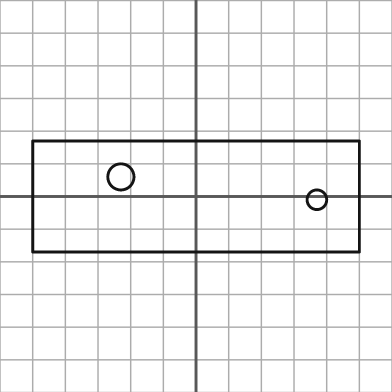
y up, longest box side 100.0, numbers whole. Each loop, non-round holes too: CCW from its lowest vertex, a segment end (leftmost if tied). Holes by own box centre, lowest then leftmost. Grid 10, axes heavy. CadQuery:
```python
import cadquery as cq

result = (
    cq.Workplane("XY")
    .moveTo(-50.0, -17.0)
    .lineTo(50.0, -17.0)
    .lineTo(50.0, 17.0)
    .lineTo(-50.0, 17.0)
    .close()
    .moveTo(37.0, -1.0)
    .circle(3.0)
    .moveTo(-23.0, 6.0)
    .circle(4.0)
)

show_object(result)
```